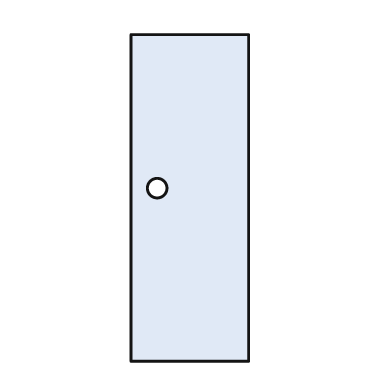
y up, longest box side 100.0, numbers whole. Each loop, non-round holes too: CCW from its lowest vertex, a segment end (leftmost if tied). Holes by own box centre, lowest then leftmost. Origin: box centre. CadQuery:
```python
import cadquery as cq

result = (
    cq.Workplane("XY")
    .moveTo(-18.0, -50.0)
    .lineTo(18.0, -50.0)
    .lineTo(18.0, 50.0)
    .lineTo(-18.0, 50.0)
    .close()
    .moveTo(-10.0, 3.0)
    .circle(3.0)
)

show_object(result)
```